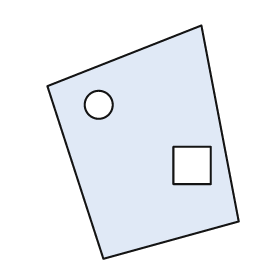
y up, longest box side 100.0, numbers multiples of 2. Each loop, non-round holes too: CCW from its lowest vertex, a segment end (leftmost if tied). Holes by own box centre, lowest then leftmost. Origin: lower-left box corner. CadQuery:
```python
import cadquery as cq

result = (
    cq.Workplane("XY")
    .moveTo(24.0, 0.0)
    .lineTo(82.0, 16.0)
    .lineTo(66.0, 100.0)
    .lineTo(0.0, 74.0)
    .close()
    .moveTo(54.0, 32.0)
    .lineTo(70.0, 32.0)
    .lineTo(70.0, 48.0)
    .lineTo(54.0, 48.0)
    .close()
    .moveTo(22.0, 66.0)
    .circle(6.0)
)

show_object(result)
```